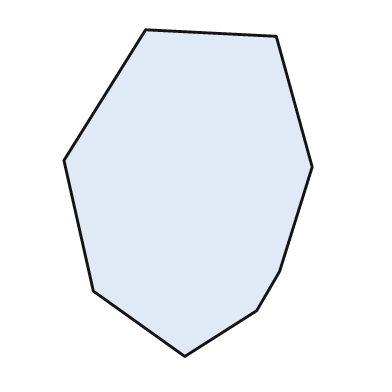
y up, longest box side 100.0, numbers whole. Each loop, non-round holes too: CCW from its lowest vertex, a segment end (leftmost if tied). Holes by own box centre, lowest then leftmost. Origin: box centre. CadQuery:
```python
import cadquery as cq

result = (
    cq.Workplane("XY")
    .moveTo(-1.0, -50.0)
    .lineTo(21.0, -36.0)
    .lineTo(28.0, -24.0)
    .lineTo(38.0, 8.0)
    .lineTo(27.0, 48.0)
    .lineTo(-13.0, 50.0)
    .lineTo(-38.0, 10.0)
    .lineTo(-29.0, -30.0)
    .close()
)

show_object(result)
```